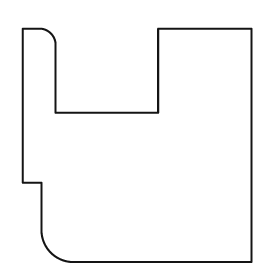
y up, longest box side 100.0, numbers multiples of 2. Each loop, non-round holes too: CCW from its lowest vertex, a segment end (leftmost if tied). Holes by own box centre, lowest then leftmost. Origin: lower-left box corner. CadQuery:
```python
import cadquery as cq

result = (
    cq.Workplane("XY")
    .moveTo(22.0, 0.0)
    .lineTo(98.0, 0.0)
    .lineTo(98.0, 100.0)
    .lineTo(58.0, 100.0)
    .lineTo(58.0, 64.0)
    .lineTo(14.0, 64.0)
    .lineTo(14.0, 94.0)
    .threePointArc((12.0, 98.0), (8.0, 100.0))
    .lineTo(0.0, 100.0)
    .lineTo(0.0, 34.0)
    .lineTo(8.0, 34.0)
    .lineTo(8.0, 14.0)
    .threePointArc((12.0, 4.0), (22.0, 0.0))
    .close()
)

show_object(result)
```